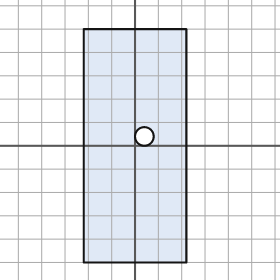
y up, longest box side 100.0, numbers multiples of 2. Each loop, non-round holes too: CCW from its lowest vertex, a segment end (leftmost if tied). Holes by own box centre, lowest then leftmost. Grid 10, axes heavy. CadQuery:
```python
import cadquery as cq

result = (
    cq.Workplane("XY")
    .moveTo(-22.0, -50.0)
    .lineTo(22.0, -50.0)
    .lineTo(22.0, 50.0)
    .lineTo(-22.0, 50.0)
    .close()
    .moveTo(4.0, 4.0)
    .circle(4.0)
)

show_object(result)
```